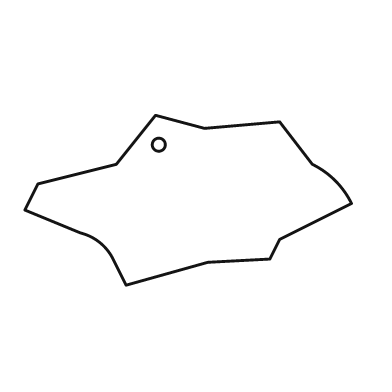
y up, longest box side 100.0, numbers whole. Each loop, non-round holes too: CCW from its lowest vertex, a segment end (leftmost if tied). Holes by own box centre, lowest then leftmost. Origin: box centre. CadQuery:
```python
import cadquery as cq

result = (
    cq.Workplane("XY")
    .moveTo(-19.0, -26.0)
    .lineTo(6.0, -19.0)
    .lineTo(25.0, -18.0)
    .lineTo(28.0, -12.0)
    .lineTo(50.0, -1.0)
    .threePointArc((45.0, 6.0), (38.0, 11.0))
    .lineTo(28.0, 24.0)
    .lineTo(5.0, 22.0)
    .lineTo(-10.0, 26.0)
    .lineTo(-22.0, 11.0)
    .lineTo(-46.0, 5.0)
    .lineTo(-50.0, -3.0)
    .lineTo(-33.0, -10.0)
    .threePointArc((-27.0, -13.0), (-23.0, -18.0))
    .close()
    .moveTo(-9.0, 17.0)
    .circle(2.0)
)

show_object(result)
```